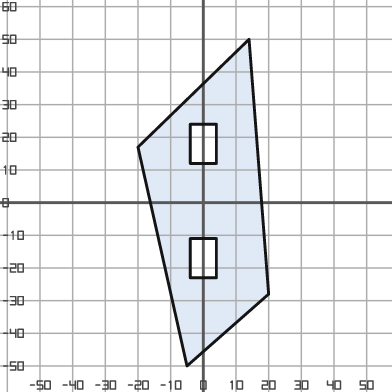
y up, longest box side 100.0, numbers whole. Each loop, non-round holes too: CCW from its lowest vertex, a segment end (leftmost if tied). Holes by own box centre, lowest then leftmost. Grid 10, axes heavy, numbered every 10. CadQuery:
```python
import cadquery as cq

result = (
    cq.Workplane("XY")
    .moveTo(-5.0, -50.0)
    .lineTo(20.0, -28.0)
    .lineTo(14.0, 50.0)
    .lineTo(-20.0, 17.0)
    .close()
    .moveTo(-4.0, -23.0)
    .lineTo(4.0, -23.0)
    .lineTo(4.0, -11.0)
    .lineTo(-4.0, -11.0)
    .close()
    .moveTo(-4.0, 12.0)
    .lineTo(4.0, 12.0)
    .lineTo(4.0, 24.0)
    .lineTo(-4.0, 24.0)
    .close()
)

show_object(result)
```